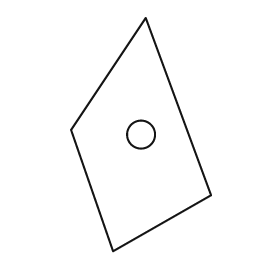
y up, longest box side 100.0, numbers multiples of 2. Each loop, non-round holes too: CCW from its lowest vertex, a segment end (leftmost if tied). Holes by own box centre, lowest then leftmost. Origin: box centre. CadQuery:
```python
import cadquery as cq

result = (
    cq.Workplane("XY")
    .moveTo(-12.0, -50.0)
    .lineTo(30.0, -26.0)
    .lineTo(2.0, 50.0)
    .lineTo(-30.0, 2.0)
    .close()
    .moveTo(0.0, 0.0)
    .circle(6.0)
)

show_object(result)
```